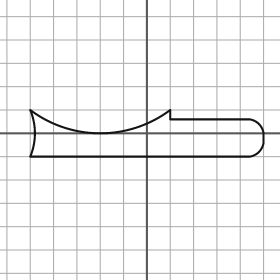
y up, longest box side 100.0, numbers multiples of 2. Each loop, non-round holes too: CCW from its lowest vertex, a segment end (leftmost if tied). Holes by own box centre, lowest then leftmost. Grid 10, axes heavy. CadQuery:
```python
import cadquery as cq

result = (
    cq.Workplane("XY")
    .moveTo(-50.0, -10.0)
    .lineTo(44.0, -10.0)
    .threePointArc((48.0, -8.0), (50.0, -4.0))
    .lineTo(50.0, 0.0)
    .threePointArc((48.0, 4.0), (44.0, 6.0))
    .lineTo(10.0, 6.0)
    .lineTo(10.0, 10.0)
    .threePointArc((-20.0, 0.0), (-50.0, 10.0))
    .threePointArc((-48.0, 0.0), (-50.0, -10.0))
    .close()
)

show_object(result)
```